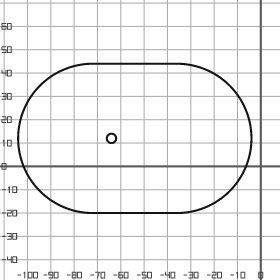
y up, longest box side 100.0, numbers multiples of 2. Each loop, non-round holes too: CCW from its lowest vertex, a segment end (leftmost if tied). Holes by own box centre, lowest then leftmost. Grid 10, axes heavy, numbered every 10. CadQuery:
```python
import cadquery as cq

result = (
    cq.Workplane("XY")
    .moveTo(-72.0, -20.0)
    .lineTo(-36.0, -20.0)
    .threePointArc((-4.0, 12.0), (-36.0, 44.0))
    .lineTo(-72.0, 44.0)
    .threePointArc((-104.0, 12.0), (-72.0, -20.0))
    .close()
    .moveTo(-64.0, 12.0)
    .circle(2.0)
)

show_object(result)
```